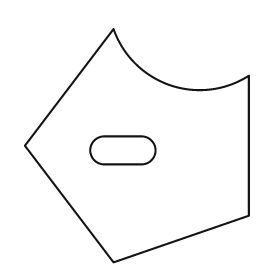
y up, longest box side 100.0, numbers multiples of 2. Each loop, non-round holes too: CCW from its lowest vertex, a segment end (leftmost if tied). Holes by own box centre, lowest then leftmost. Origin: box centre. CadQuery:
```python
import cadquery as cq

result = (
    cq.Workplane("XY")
    .moveTo(-10.0, -50.0)
    .lineTo(48.0, -30.0)
    .lineTo(48.0, 30.0)
    .threePointArc((14.0, 26.0), (-10.0, 50.0))
    .lineTo(-48.0, 0.0)
    .close()
    .moveTo(-14.0, -8.0)
    .lineTo(2.0, -8.0)
    .threePointArc((8.0, -2.0), (2.0, 4.0))
    .lineTo(-14.0, 4.0)
    .threePointArc((-20.0, -2.0), (-14.0, -8.0))
    .close()
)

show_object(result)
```